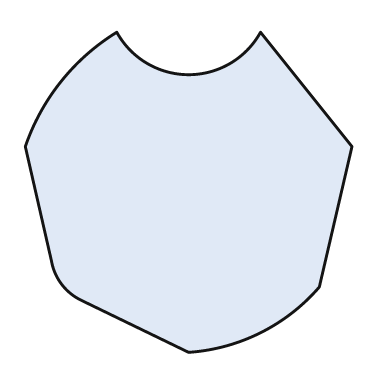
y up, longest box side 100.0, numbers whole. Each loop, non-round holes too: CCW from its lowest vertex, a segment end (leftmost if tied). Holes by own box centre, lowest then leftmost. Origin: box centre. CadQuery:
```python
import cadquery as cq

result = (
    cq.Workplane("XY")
    .moveTo(0.0, -49.0)
    .threePointArc((22.0, -43.0), (40.0, -29.0))
    .lineTo(50.0, 14.0)
    .lineTo(22.0, 49.0)
    .threePointArc((0.0, 36.0), (-22.0, 49.0))
    .threePointArc((-39.0, 34.0), (-50.0, 14.0))
    .lineTo(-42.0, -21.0)
    .threePointArc((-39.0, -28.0), (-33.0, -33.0))
    .close()
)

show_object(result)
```